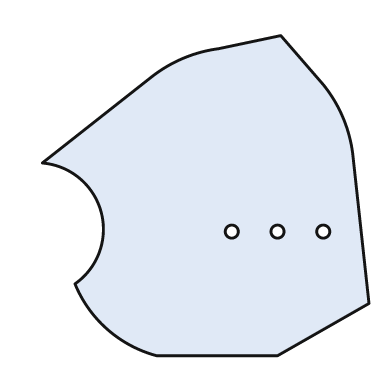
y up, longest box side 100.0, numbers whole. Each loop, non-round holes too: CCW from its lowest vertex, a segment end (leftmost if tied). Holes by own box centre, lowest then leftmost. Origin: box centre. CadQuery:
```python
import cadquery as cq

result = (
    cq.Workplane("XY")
    .moveTo(-15.0, -49.0)
    .lineTo(22.0, -49.0)
    .lineTo(50.0, -33.0)
    .lineTo(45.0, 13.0)
    .threePointArc((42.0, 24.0), (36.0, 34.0))
    .lineTo(23.0, 49.0)
    .lineTo(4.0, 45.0)
    .threePointArc((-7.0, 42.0), (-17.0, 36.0))
    .lineTo(-50.0, 10.0)
    .threePointArc((-32.0, -5.0), (-40.0, -27.0))
    .threePointArc((-30.0, -41.0), (-15.0, -49.0))
    .close()
    .moveTo(8.0, -11.0)
    .circle(2.0)
    .moveTo(22.0, -11.0)
    .circle(2.0)
    .moveTo(36.0, -11.0)
    .circle(2.0)
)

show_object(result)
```